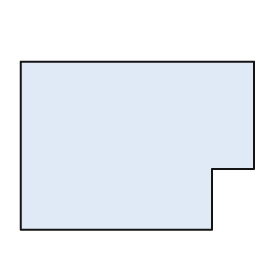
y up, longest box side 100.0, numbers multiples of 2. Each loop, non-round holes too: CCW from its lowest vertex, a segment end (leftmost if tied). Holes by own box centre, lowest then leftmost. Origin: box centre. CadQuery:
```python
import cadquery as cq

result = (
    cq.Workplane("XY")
    .moveTo(-50.0, -36.0)
    .lineTo(32.0, -36.0)
    .lineTo(32.0, -10.0)
    .lineTo(50.0, -10.0)
    .lineTo(50.0, 36.0)
    .lineTo(-50.0, 36.0)
    .close()
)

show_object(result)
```